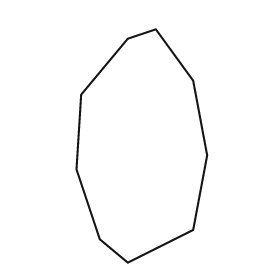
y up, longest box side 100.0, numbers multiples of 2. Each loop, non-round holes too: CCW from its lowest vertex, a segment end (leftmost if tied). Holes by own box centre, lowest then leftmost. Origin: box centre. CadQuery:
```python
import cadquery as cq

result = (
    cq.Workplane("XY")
    .moveTo(-6.0, -50.0)
    .lineTo(22.0, -36.0)
    .lineTo(28.0, -4.0)
    .lineTo(22.0, 28.0)
    .lineTo(6.0, 50.0)
    .lineTo(-6.0, 46.0)
    .lineTo(-26.0, 22.0)
    .lineTo(-28.0, -10.0)
    .lineTo(-18.0, -40.0)
    .close()
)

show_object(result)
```